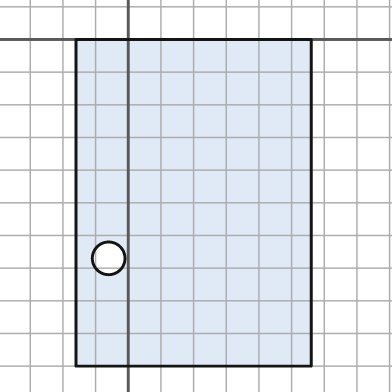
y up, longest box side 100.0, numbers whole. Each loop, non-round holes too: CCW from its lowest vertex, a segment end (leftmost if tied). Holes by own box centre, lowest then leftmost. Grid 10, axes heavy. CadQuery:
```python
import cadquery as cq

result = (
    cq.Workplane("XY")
    .moveTo(-16.0, -100.0)
    .lineTo(56.0, -100.0)
    .lineTo(56.0, 0.0)
    .lineTo(-16.0, 0.0)
    .close()
    .moveTo(-6.0, -67.0)
    .circle(5.0)
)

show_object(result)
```